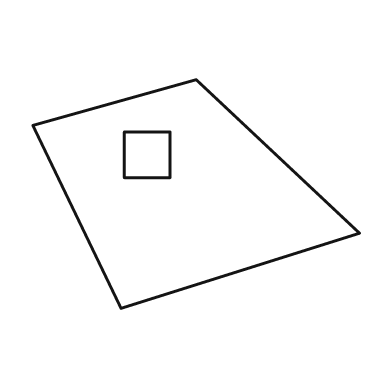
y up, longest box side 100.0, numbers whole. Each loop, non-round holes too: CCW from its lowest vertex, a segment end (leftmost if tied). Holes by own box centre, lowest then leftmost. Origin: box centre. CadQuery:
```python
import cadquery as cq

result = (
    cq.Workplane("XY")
    .moveTo(-23.0, -35.0)
    .lineTo(50.0, -12.0)
    .lineTo(0.0, 35.0)
    .lineTo(-50.0, 21.0)
    .close()
    .moveTo(-22.0, 5.0)
    .lineTo(-8.0, 5.0)
    .lineTo(-8.0, 19.0)
    .lineTo(-22.0, 19.0)
    .close()
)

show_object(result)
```